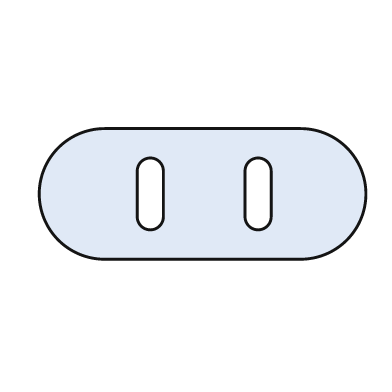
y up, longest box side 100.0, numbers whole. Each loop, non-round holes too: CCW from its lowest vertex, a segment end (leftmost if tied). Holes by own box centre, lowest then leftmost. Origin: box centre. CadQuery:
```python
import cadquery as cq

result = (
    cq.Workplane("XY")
    .moveTo(-30.0, -20.0)
    .lineTo(30.0, -20.0)
    .threePointArc((50.0, 0.0), (30.0, 20.0))
    .lineTo(-30.0, 20.0)
    .threePointArc((-50.0, 0.0), (-30.0, -20.0))
    .close()
    .moveTo(-20.0, -7.0)
    .threePointArc((-16.0, -11.0), (-12.0, -7.0))
    .lineTo(-12.0, 7.0)
    .threePointArc((-16.0, 11.0), (-20.0, 7.0))
    .close()
    .moveTo(13.0, -7.0)
    .threePointArc((17.0, -11.0), (21.0, -7.0))
    .lineTo(21.0, 7.0)
    .threePointArc((17.0, 11.0), (13.0, 7.0))
    .close()
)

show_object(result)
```